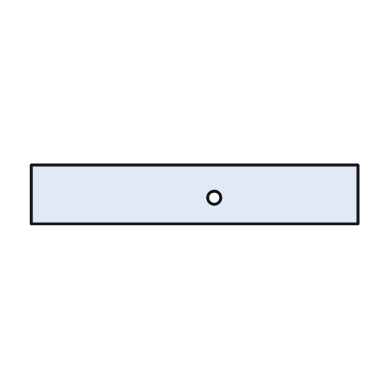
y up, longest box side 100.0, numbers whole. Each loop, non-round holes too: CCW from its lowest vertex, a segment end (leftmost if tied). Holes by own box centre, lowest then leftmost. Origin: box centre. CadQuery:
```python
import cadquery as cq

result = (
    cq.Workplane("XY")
    .moveTo(-50.0, -9.0)
    .lineTo(50.0, -9.0)
    .lineTo(50.0, 9.0)
    .lineTo(-50.0, 9.0)
    .close()
    .moveTo(6.0, -1.0)
    .circle(2.0)
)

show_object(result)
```